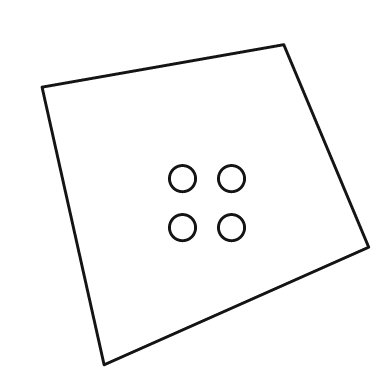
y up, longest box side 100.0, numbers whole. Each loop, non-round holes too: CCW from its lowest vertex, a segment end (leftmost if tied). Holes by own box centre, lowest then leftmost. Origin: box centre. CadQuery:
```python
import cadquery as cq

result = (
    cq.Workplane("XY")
    .moveTo(-31.0, -49.0)
    .lineTo(50.0, -13.0)
    .lineTo(24.0, 49.0)
    .lineTo(-50.0, 36.0)
    .close()
    .moveTo(-7.0, -7.0)
    .circle(4.0)
    .moveTo(8.0, -7.0)
    .circle(4.0)
    .moveTo(-7.0, 8.0)
    .circle(4.0)
    .moveTo(8.0, 8.0)
    .circle(4.0)
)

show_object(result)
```